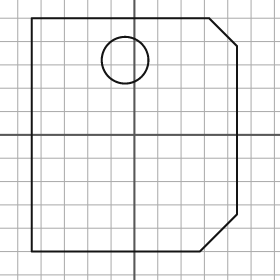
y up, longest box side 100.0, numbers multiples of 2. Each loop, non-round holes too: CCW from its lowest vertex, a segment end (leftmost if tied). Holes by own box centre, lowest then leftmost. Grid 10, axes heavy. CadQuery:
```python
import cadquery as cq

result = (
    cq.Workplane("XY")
    .moveTo(-44.0, -50.0)
    .lineTo(28.0, -50.0)
    .lineTo(44.0, -34.0)
    .lineTo(44.0, 38.0)
    .lineTo(32.0, 50.0)
    .lineTo(-44.0, 50.0)
    .close()
    .moveTo(-4.0, 32.0)
    .circle(10.0)
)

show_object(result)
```